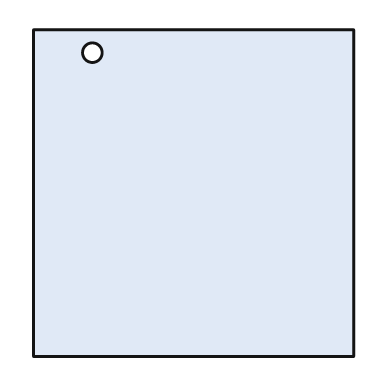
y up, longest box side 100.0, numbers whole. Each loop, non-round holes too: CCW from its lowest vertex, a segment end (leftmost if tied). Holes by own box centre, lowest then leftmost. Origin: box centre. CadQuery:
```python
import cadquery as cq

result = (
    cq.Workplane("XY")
    .moveTo(-49.0, -50.0)
    .lineTo(49.0, -50.0)
    .lineTo(49.0, 50.0)
    .lineTo(-49.0, 50.0)
    .close()
    .moveTo(-31.0, 43.0)
    .circle(3.0)
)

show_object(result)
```